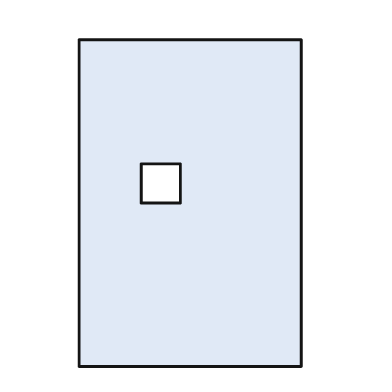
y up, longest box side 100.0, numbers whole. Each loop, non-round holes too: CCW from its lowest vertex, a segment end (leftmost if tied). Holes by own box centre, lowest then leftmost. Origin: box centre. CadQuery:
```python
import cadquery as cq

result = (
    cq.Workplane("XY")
    .moveTo(-34.0, -50.0)
    .lineTo(34.0, -50.0)
    .lineTo(34.0, 50.0)
    .lineTo(-34.0, 50.0)
    .close()
    .moveTo(-15.0, 0.0)
    .lineTo(-3.0, 0.0)
    .lineTo(-3.0, 12.0)
    .lineTo(-15.0, 12.0)
    .close()
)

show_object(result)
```